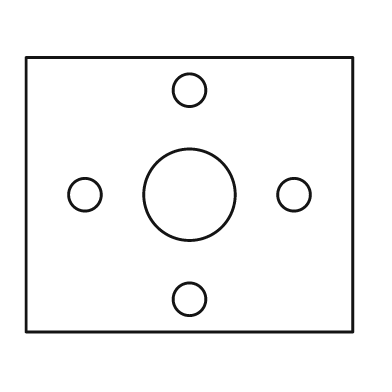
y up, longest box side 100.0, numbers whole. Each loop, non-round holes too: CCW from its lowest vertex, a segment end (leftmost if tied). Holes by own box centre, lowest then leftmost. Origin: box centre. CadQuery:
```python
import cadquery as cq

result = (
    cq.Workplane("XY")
    .moveTo(-50.0, -42.0)
    .lineTo(50.0, -42.0)
    .lineTo(50.0, 42.0)
    .lineTo(-50.0, 42.0)
    .close()
    .moveTo(0.0, -32.0)
    .circle(5.0)
    .moveTo(-32.0, 0.0)
    .circle(5.0)
    .moveTo(0.0, 0.0)
    .circle(14.0)
    .moveTo(32.0, 0.0)
    .circle(5.0)
    .moveTo(0.0, 32.0)
    .circle(5.0)
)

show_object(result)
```